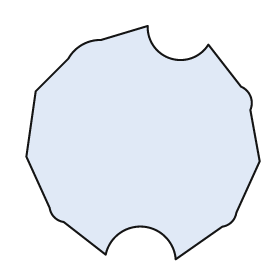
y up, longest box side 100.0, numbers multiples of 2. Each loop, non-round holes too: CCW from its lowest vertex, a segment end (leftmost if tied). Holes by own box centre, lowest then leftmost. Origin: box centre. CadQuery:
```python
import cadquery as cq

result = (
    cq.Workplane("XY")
    .moveTo(14.0, -50.0)
    .lineTo(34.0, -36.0)
    .threePointArc((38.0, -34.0), (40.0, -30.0))
    .lineTo(50.0, -8.0)
    .lineTo(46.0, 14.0)
    .threePointArc((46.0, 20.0), (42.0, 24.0))
    .lineTo(28.0, 42.0)
    .threePointArc((12.0, 36.0), (2.0, 50.0))
    .lineTo(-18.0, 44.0)
    .threePointArc((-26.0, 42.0), (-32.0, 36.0))
    .lineTo(-46.0, 22.0)
    .lineTo(-50.0, -6.0)
    .lineTo(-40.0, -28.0)
    .threePointArc((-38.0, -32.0), (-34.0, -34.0))
    .lineTo(-16.0, -48.0)
    .threePointArc((0.0, -36.0), (14.0, -50.0))
    .close()
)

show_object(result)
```